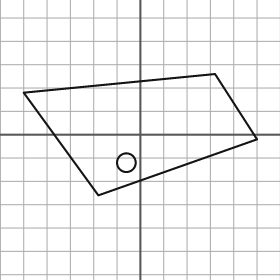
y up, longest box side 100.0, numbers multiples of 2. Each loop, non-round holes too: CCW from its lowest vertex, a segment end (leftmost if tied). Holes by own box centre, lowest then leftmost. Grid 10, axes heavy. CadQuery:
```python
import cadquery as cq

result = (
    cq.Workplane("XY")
    .moveTo(-18.0, -26.0)
    .lineTo(50.0, -2.0)
    .lineTo(32.0, 26.0)
    .lineTo(-50.0, 18.0)
    .close()
    .moveTo(-6.0, -12.0)
    .circle(4.0)
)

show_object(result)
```